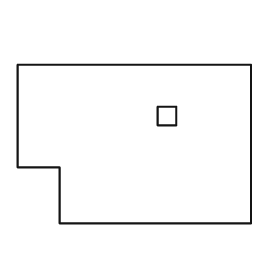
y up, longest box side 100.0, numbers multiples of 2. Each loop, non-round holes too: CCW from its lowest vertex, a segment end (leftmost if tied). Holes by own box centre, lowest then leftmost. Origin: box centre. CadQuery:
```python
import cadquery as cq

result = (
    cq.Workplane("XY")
    .moveTo(-32.0, -34.0)
    .lineTo(50.0, -34.0)
    .lineTo(50.0, 34.0)
    .lineTo(-50.0, 34.0)
    .lineTo(-50.0, -10.0)
    .lineTo(-32.0, -10.0)
    .close()
    .moveTo(10.0, 8.0)
    .lineTo(18.0, 8.0)
    .lineTo(18.0, 16.0)
    .lineTo(10.0, 16.0)
    .close()
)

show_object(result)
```